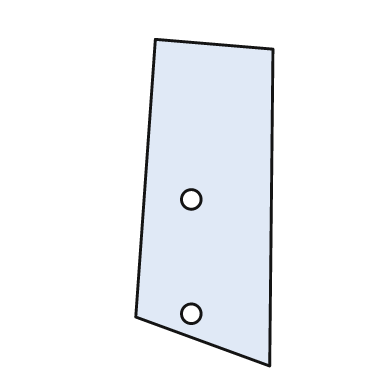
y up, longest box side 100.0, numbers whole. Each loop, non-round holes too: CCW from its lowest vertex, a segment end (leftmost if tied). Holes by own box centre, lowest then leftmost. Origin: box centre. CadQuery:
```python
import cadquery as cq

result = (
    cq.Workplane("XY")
    .moveTo(20.0, -50.0)
    .lineTo(21.0, 47.0)
    .lineTo(-15.0, 50.0)
    .lineTo(-21.0, -35.0)
    .close()
    .moveTo(-4.0, -34.0)
    .circle(3.0)
    .moveTo(-4.0, 1.0)
    .circle(3.0)
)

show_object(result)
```